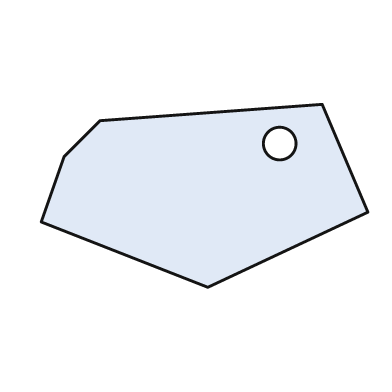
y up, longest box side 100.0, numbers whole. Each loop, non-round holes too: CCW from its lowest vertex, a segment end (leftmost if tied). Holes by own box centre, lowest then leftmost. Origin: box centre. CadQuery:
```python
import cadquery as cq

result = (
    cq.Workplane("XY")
    .moveTo(1.0, -28.0)
    .lineTo(50.0, -5.0)
    .lineTo(36.0, 28.0)
    .lineTo(-32.0, 23.0)
    .lineTo(-43.0, 12.0)
    .lineTo(-50.0, -8.0)
    .close()
    .moveTo(23.0, 16.0)
    .circle(5.0)
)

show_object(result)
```